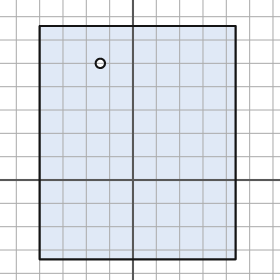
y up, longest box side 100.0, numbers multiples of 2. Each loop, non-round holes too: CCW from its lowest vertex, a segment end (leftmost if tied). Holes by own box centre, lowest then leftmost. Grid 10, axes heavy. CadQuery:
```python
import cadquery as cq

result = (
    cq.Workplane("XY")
    .moveTo(-40.0, -34.0)
    .lineTo(44.0, -34.0)
    .lineTo(44.0, 66.0)
    .lineTo(-40.0, 66.0)
    .close()
    .moveTo(-14.0, 50.0)
    .circle(2.0)
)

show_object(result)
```